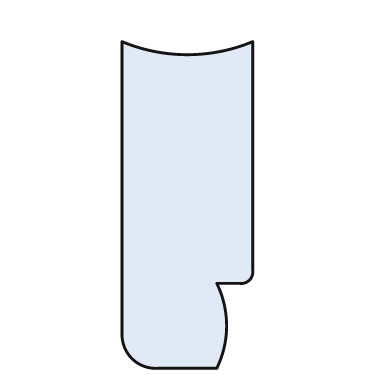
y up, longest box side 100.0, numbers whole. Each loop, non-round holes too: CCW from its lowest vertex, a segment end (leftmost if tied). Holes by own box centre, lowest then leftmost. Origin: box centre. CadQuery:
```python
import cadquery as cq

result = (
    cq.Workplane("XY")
    .moveTo(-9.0, -50.0)
    .lineTo(9.0, -50.0)
    .threePointArc((12.0, -37.0), (9.0, -24.0))
    .lineTo(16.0, -24.0)
    .threePointArc((19.0, -23.0), (20.0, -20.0))
    .lineTo(20.0, 50.0)
    .threePointArc((0.0, 46.0), (-20.0, 50.0))
    .lineTo(-20.0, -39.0)
    .threePointArc((-17.0, -47.0), (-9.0, -50.0))
    .close()
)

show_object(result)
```